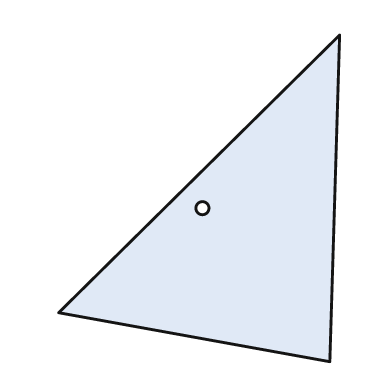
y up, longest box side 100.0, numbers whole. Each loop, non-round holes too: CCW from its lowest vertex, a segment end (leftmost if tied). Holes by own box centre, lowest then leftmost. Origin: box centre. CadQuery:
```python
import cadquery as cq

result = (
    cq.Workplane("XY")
    .moveTo(40.0, -50.0)
    .lineTo(43.0, 50.0)
    .lineTo(-43.0, -35.0)
    .close()
    .moveTo(1.0, -3.0)
    .circle(2.0)
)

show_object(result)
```